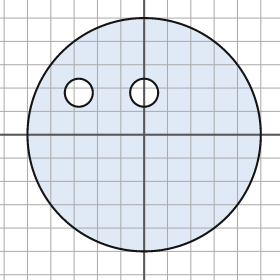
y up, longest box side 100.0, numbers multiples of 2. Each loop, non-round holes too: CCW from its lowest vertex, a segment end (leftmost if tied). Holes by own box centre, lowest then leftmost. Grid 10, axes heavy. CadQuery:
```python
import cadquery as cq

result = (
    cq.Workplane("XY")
    .moveTo(0.0, 0.0)
    .circle(50.0)
    .moveTo(-28.0, 18.0)
    .circle(6.0)
    .moveTo(0.0, 18.0)
    .circle(6.0)
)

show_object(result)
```